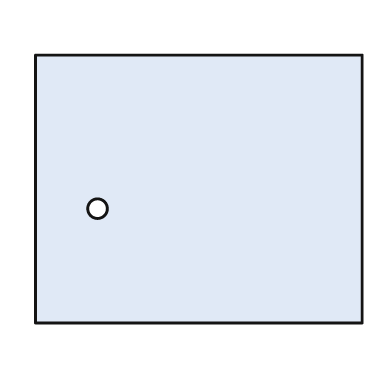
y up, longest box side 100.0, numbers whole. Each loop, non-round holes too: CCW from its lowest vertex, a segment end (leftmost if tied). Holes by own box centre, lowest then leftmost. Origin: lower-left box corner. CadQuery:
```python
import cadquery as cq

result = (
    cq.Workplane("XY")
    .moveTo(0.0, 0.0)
    .lineTo(100.0, 0.0)
    .lineTo(100.0, 82.0)
    .lineTo(0.0, 82.0)
    .close()
    .moveTo(19.0, 35.0)
    .circle(3.0)
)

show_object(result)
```